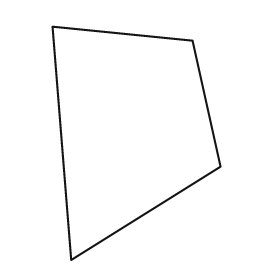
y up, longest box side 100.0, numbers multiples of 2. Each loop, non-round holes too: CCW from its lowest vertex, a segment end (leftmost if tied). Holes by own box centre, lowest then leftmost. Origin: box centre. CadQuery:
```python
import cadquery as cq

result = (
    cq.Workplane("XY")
    .moveTo(-28.0, -50.0)
    .lineTo(36.0, -10.0)
    .lineTo(24.0, 44.0)
    .lineTo(-36.0, 50.0)
    .close()
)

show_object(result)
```